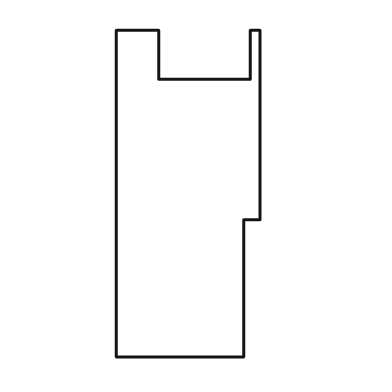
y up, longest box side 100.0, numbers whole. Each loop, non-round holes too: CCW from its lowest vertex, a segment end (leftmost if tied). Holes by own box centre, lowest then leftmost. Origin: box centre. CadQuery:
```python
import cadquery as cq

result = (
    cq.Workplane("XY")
    .moveTo(-22.0, -50.0)
    .lineTo(17.0, -50.0)
    .lineTo(17.0, -8.0)
    .lineTo(22.0, -8.0)
    .lineTo(22.0, 50.0)
    .lineTo(19.0, 50.0)
    .lineTo(19.0, 35.0)
    .lineTo(-9.0, 35.0)
    .lineTo(-9.0, 50.0)
    .lineTo(-22.0, 50.0)
    .close()
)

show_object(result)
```